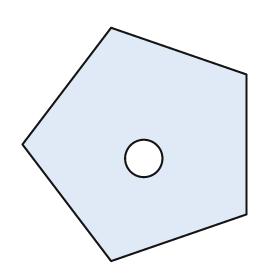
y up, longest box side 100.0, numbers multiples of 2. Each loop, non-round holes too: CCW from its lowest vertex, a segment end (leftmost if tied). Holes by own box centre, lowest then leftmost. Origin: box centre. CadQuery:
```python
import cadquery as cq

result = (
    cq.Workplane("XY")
    .moveTo(-10.0, -50.0)
    .lineTo(48.0, -30.0)
    .lineTo(48.0, 30.0)
    .lineTo(-10.0, 50.0)
    .lineTo(-48.0, 0.0)
    .close()
    .moveTo(4.0, -6.0)
    .circle(8.0)
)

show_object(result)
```